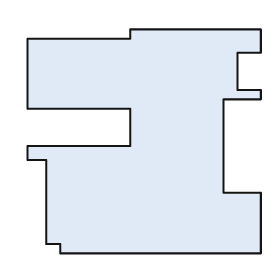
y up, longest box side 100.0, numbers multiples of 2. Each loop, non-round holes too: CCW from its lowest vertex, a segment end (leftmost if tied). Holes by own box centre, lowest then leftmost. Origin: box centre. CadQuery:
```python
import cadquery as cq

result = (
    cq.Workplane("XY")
    .moveTo(-36.0, -48.0)
    .lineTo(50.0, -48.0)
    .lineTo(50.0, -22.0)
    .lineTo(34.0, -22.0)
    .lineTo(34.0, 18.0)
    .lineTo(50.0, 18.0)
    .lineTo(50.0, 22.0)
    .lineTo(40.0, 22.0)
    .lineTo(40.0, 38.0)
    .lineTo(50.0, 38.0)
    .lineTo(50.0, 48.0)
    .lineTo(-6.0, 48.0)
    .lineTo(-6.0, 44.0)
    .lineTo(-50.0, 44.0)
    .lineTo(-50.0, 14.0)
    .lineTo(-6.0, 14.0)
    .lineTo(-6.0, -2.0)
    .lineTo(-50.0, -2.0)
    .lineTo(-50.0, -8.0)
    .lineTo(-42.0, -8.0)
    .lineTo(-42.0, -44.0)
    .lineTo(-36.0, -44.0)
    .close()
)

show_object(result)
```